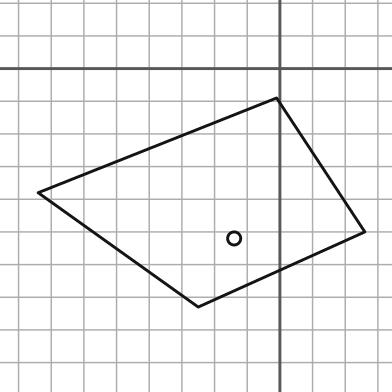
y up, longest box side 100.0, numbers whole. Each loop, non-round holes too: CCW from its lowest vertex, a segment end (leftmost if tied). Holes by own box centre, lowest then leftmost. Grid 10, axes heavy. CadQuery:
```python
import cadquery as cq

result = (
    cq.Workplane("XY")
    .moveTo(-25.0, -73.0)
    .lineTo(26.0, -50.0)
    .lineTo(-1.0, -9.0)
    .lineTo(-74.0, -38.0)
    .close()
    .moveTo(-14.0, -52.0)
    .circle(2.0)
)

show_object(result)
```